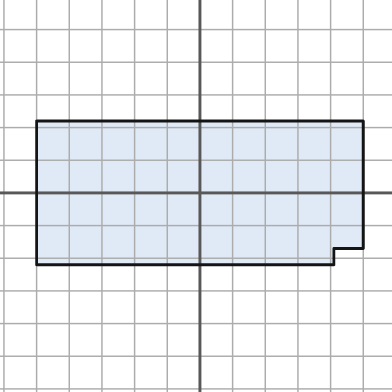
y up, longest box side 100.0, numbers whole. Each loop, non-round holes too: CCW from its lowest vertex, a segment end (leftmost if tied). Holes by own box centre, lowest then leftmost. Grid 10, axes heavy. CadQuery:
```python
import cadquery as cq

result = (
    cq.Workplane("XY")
    .moveTo(-50.0, -22.0)
    .lineTo(41.0, -22.0)
    .lineTo(41.0, -17.0)
    .lineTo(50.0, -17.0)
    .lineTo(50.0, 22.0)
    .lineTo(-50.0, 22.0)
    .close()
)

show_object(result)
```